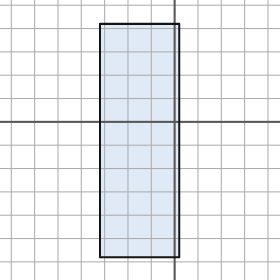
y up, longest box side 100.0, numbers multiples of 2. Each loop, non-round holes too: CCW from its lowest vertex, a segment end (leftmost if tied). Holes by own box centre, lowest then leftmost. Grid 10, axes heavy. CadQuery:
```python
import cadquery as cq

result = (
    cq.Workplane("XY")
    .moveTo(-32.0, -58.0)
    .lineTo(2.0, -58.0)
    .lineTo(2.0, 42.0)
    .lineTo(-32.0, 42.0)
    .close()
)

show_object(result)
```